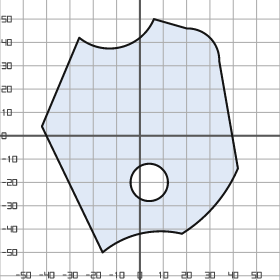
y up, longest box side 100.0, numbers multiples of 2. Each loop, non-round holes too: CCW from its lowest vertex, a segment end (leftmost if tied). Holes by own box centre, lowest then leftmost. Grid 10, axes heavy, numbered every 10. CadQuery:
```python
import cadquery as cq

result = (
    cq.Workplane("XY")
    .moveTo(-16.0, -50.0)
    .threePointArc((0.0, -42.0), (18.0, -42.0))
    .threePointArc((32.0, -30.0), (42.0, -14.0))
    .lineTo(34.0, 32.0)
    .threePointArc((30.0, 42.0), (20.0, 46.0))
    .lineTo(6.0, 50.0)
    .threePointArc((-8.0, 38.0), (-26.0, 42.0))
    .lineTo(-42.0, 4.0)
    .close()
    .moveTo(4.0, -20.0)
    .circle(8.0)
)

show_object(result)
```